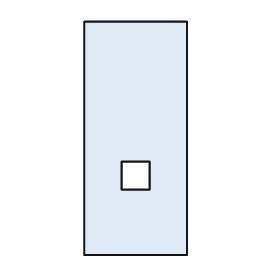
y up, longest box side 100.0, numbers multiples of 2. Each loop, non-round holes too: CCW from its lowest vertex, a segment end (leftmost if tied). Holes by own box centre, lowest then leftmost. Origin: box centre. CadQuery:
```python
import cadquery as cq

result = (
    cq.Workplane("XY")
    .moveTo(-22.0, -50.0)
    .lineTo(22.0, -50.0)
    .lineTo(22.0, 50.0)
    .lineTo(-22.0, 50.0)
    .close()
    .moveTo(-6.0, -22.0)
    .lineTo(6.0, -22.0)
    .lineTo(6.0, -10.0)
    .lineTo(-6.0, -10.0)
    .close()
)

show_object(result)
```